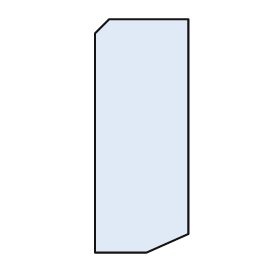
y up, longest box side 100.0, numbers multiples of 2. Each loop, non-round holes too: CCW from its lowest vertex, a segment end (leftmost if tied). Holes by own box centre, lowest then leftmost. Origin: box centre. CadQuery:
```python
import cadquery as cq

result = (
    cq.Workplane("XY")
    .moveTo(-20.0, -50.0)
    .lineTo(2.0, -50.0)
    .lineTo(20.0, -42.0)
    .lineTo(20.0, 50.0)
    .lineTo(-14.0, 50.0)
    .lineTo(-20.0, 44.0)
    .close()
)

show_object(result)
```